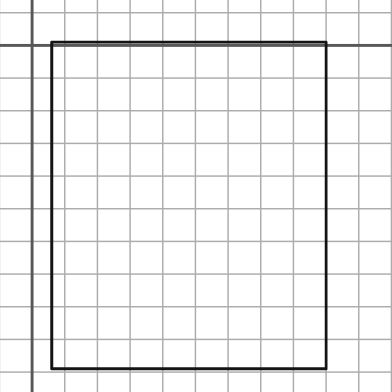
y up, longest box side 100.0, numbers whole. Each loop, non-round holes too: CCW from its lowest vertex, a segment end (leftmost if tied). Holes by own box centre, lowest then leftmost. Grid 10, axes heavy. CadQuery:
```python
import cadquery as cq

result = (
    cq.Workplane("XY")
    .moveTo(6.0, -99.0)
    .lineTo(90.0, -99.0)
    .lineTo(90.0, 1.0)
    .lineTo(6.0, 1.0)
    .close()
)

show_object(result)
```